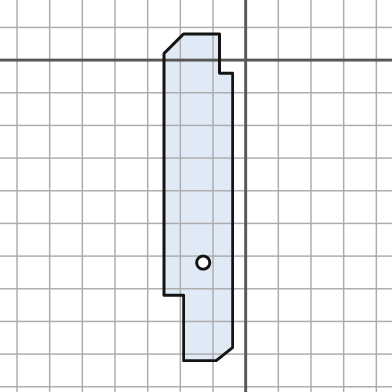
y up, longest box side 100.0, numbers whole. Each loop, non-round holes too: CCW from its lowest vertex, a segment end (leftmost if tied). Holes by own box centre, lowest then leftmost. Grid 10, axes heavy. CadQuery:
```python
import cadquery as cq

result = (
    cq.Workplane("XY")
    .moveTo(-19.0, -92.0)
    .lineTo(-9.0, -92.0)
    .lineTo(-4.0, -88.0)
    .lineTo(-4.0, -4.0)
    .lineTo(-8.0, -4.0)
    .lineTo(-8.0, 8.0)
    .lineTo(-19.0, 8.0)
    .lineTo(-25.0, 2.0)
    .lineTo(-25.0, -72.0)
    .lineTo(-19.0, -72.0)
    .close()
    .moveTo(-13.0, -62.0)
    .circle(2.0)
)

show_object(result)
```